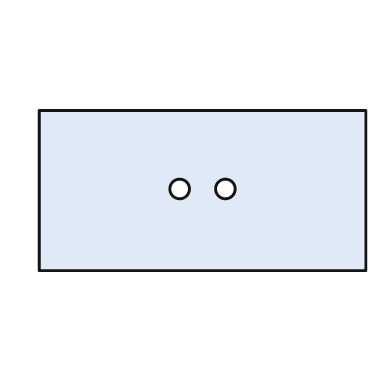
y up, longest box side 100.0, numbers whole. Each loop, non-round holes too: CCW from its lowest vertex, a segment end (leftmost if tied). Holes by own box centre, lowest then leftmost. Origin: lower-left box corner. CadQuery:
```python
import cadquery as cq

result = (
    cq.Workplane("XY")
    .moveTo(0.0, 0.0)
    .lineTo(100.0, 0.0)
    .lineTo(100.0, 49.0)
    .lineTo(0.0, 49.0)
    .close()
    .moveTo(43.0, 25.0)
    .circle(3.0)
    .moveTo(57.0, 25.0)
    .circle(3.0)
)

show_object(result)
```